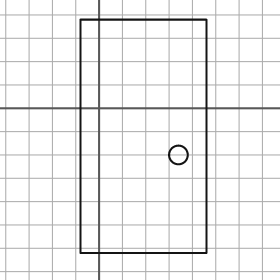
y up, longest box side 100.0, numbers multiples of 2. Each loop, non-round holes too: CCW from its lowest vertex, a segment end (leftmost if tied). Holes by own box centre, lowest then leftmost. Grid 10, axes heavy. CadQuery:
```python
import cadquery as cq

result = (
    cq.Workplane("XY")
    .moveTo(-8.0, -62.0)
    .lineTo(46.0, -62.0)
    .lineTo(46.0, 38.0)
    .lineTo(-8.0, 38.0)
    .close()
    .moveTo(34.0, -20.0)
    .circle(4.0)
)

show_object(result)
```